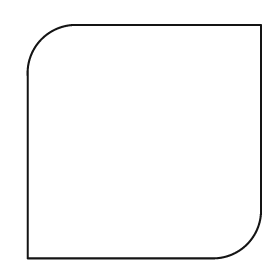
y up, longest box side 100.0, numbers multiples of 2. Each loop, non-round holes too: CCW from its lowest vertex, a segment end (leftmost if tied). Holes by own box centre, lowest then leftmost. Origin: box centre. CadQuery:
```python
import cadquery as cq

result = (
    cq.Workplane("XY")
    .moveTo(-50.0, -50.0)
    .lineTo(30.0, -50.0)
    .threePointArc((44.0, -44.0), (50.0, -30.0))
    .lineTo(50.0, 50.0)
    .lineTo(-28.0, 50.0)
    .threePointArc((-44.0, 44.0), (-50.0, 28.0))
    .close()
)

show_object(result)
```